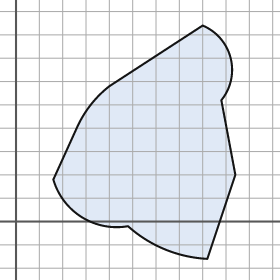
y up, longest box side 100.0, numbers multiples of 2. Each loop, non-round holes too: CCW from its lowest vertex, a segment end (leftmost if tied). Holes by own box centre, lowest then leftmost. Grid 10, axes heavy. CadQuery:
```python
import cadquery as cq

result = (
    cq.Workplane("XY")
    .moveTo(82.0, -16.0)
    .lineTo(94.0, 20.0)
    .lineTo(88.0, 52.0)
    .threePointArc((92.0, 70.0), (80.0, 84.0))
    .lineTo(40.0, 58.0)
    .threePointArc((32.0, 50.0), (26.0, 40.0))
    .lineTo(16.0, 18.0)
    .threePointArc((28.0, 2.0), (48.0, -2.0))
    .threePointArc((64.0, -12.0), (82.0, -16.0))
    .close()
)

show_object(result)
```